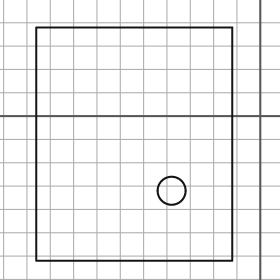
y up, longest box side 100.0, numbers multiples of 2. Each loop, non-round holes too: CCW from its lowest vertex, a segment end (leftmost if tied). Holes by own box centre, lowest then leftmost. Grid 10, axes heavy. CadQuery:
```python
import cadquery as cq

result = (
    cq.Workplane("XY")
    .moveTo(-96.0, -62.0)
    .lineTo(-12.0, -62.0)
    .lineTo(-12.0, 38.0)
    .lineTo(-96.0, 38.0)
    .close()
    .moveTo(-38.0, -32.0)
    .circle(6.0)
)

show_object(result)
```